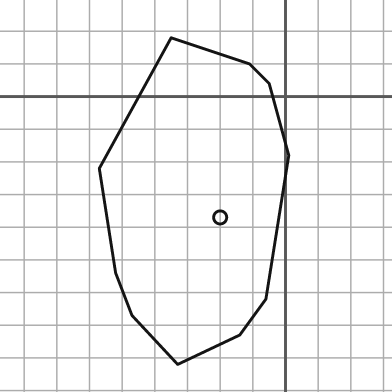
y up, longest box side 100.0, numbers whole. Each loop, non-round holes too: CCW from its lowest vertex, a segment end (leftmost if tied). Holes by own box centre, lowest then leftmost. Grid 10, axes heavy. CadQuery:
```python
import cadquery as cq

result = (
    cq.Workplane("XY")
    .moveTo(-33.0, -82.0)
    .lineTo(-14.0, -73.0)
    .lineTo(-6.0, -62.0)
    .lineTo(1.0, -18.0)
    .lineTo(-5.0, 4.0)
    .lineTo(-11.0, 10.0)
    .lineTo(-35.0, 18.0)
    .lineTo(-57.0, -22.0)
    .lineTo(-52.0, -54.0)
    .lineTo(-47.0, -67.0)
    .close()
    .moveTo(-20.0, -37.0)
    .circle(2.0)
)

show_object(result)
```